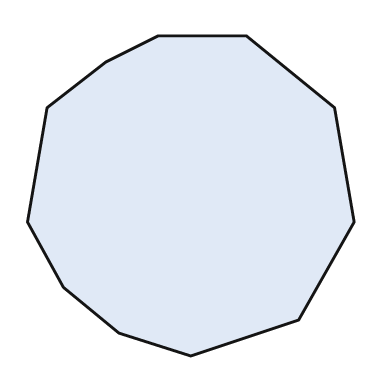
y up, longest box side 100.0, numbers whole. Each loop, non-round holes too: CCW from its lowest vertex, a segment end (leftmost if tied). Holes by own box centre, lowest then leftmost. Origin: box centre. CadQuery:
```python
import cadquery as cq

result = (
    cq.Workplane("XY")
    .moveTo(0.0, -49.0)
    .lineTo(33.0, -38.0)
    .lineTo(50.0, -8.0)
    .lineTo(44.0, 27.0)
    .lineTo(17.0, 49.0)
    .lineTo(-10.0, 49.0)
    .lineTo(-26.0, 41.0)
    .lineTo(-44.0, 27.0)
    .lineTo(-50.0, -8.0)
    .lineTo(-39.0, -28.0)
    .lineTo(-22.0, -42.0)
    .close()
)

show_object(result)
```